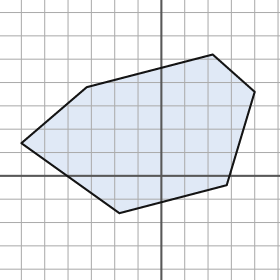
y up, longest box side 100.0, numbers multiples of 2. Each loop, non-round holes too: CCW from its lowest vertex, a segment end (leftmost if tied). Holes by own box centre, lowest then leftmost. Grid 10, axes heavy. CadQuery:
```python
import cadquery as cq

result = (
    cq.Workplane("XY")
    .moveTo(-18.0, -16.0)
    .lineTo(28.0, -4.0)
    .lineTo(40.0, 36.0)
    .lineTo(22.0, 52.0)
    .lineTo(-32.0, 38.0)
    .lineTo(-60.0, 14.0)
    .close()
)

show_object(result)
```